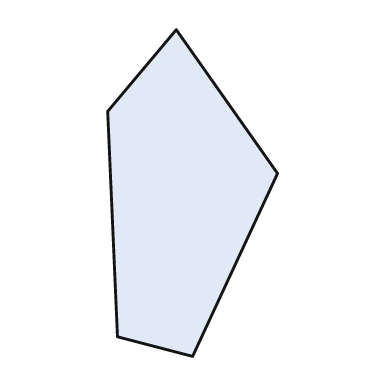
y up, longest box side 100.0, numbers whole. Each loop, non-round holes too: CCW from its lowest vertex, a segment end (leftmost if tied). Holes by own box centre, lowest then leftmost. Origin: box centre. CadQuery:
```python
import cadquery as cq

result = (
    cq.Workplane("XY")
    .moveTo(0.0, -50.0)
    .lineTo(26.0, 6.0)
    .lineTo(-5.0, 50.0)
    .lineTo(-26.0, 25.0)
    .lineTo(-23.0, -44.0)
    .close()
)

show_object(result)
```